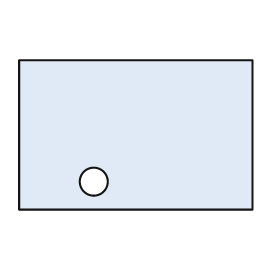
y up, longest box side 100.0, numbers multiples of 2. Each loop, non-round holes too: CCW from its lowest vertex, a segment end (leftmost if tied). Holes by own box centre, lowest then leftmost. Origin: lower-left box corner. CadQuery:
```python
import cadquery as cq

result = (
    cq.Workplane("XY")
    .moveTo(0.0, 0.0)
    .lineTo(100.0, 0.0)
    .lineTo(100.0, 64.0)
    .lineTo(0.0, 64.0)
    .close()
    .moveTo(32.0, 12.0)
    .circle(6.0)
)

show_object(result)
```